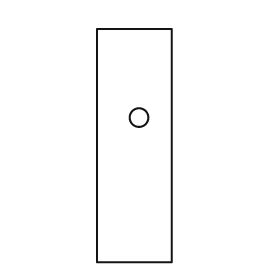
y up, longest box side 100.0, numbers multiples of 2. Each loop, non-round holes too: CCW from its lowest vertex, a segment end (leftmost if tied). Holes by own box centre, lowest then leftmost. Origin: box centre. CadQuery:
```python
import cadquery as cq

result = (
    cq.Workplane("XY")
    .moveTo(-16.0, -50.0)
    .lineTo(16.0, -50.0)
    .lineTo(16.0, 50.0)
    .lineTo(-16.0, 50.0)
    .close()
    .moveTo(2.0, 12.0)
    .circle(4.0)
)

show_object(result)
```